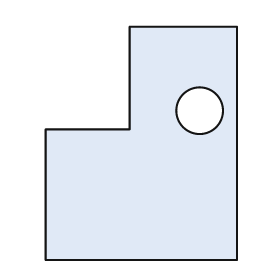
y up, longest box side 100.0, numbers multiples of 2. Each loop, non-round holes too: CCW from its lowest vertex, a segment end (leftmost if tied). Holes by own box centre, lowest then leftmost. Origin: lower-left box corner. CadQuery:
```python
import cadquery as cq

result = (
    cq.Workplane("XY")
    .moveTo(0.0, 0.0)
    .lineTo(82.0, 0.0)
    .lineTo(82.0, 100.0)
    .lineTo(36.0, 100.0)
    .lineTo(36.0, 56.0)
    .lineTo(0.0, 56.0)
    .close()
    .moveTo(66.0, 64.0)
    .circle(10.0)
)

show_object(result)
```